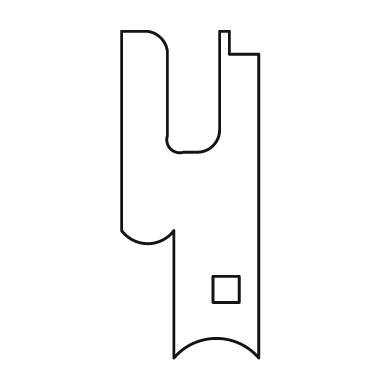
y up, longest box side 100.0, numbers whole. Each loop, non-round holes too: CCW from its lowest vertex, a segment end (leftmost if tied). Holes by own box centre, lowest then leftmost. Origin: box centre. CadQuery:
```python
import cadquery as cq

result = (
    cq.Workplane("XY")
    .moveTo(-5.0, -50.0)
    .threePointArc((8.0, -44.0), (21.0, -50.0))
    .lineTo(21.0, 43.0)
    .lineTo(12.0, 43.0)
    .lineTo(12.0, 50.0)
    .lineTo(9.0, 50.0)
    .lineTo(9.0, 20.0)
    .threePointArc((7.0, 15.0), (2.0, 13.0))
    .lineTo(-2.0, 13.0)
    .threePointArc((-6.0, 14.0), (-7.0, 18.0))
    .lineTo(-7.0, 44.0)
    .threePointArc((-9.0, 48.0), (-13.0, 50.0))
    .lineTo(-21.0, 50.0)
    .lineTo(-21.0, -11.0)
    .threePointArc((-13.0, -15.0), (-5.0, -11.0))
    .close()
    .moveTo(7.0, -33.0)
    .lineTo(15.0, -33.0)
    .lineTo(15.0, -25.0)
    .lineTo(7.0, -25.0)
    .close()
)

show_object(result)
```